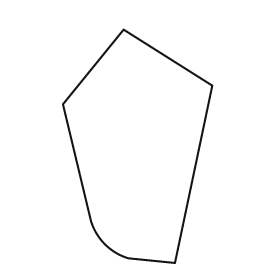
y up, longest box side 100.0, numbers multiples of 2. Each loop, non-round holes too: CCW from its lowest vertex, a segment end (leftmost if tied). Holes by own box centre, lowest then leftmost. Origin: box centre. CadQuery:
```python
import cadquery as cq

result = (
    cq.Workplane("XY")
    .moveTo(16.0, -50.0)
    .lineTo(32.0, 26.0)
    .lineTo(-6.0, 50.0)
    .lineTo(-32.0, 18.0)
    .lineTo(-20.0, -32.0)
    .threePointArc((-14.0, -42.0), (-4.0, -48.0))
    .close()
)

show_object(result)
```